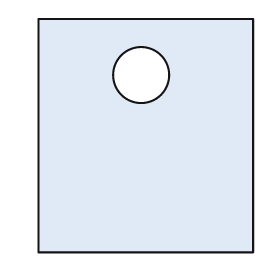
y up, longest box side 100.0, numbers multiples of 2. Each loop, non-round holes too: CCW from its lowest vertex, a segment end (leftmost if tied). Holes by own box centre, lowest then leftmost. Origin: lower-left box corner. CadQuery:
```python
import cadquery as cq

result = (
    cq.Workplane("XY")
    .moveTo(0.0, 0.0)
    .lineTo(92.0, 0.0)
    .lineTo(92.0, 100.0)
    .lineTo(0.0, 100.0)
    .close()
    .moveTo(44.0, 76.0)
    .circle(12.0)
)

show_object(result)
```